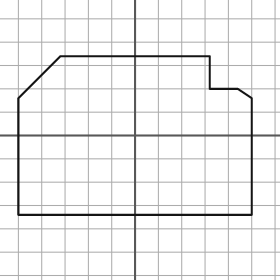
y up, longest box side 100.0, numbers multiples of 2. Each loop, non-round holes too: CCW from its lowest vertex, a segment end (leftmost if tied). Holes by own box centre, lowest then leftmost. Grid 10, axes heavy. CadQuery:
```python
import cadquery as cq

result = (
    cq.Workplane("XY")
    .moveTo(-50.0, -34.0)
    .lineTo(50.0, -34.0)
    .lineTo(50.0, 16.0)
    .lineTo(44.0, 20.0)
    .lineTo(32.0, 20.0)
    .lineTo(32.0, 34.0)
    .lineTo(-32.0, 34.0)
    .lineTo(-50.0, 16.0)
    .close()
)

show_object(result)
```